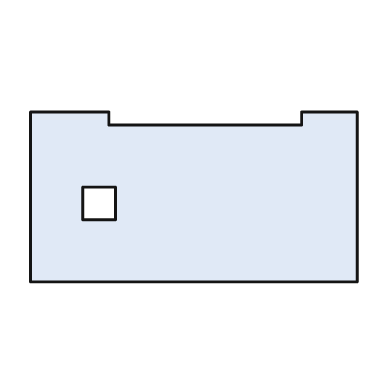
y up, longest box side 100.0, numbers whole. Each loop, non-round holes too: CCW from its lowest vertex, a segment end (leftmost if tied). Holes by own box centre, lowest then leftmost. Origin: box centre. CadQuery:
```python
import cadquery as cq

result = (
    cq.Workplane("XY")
    .moveTo(-50.0, -26.0)
    .lineTo(50.0, -26.0)
    .lineTo(50.0, 26.0)
    .lineTo(33.0, 26.0)
    .lineTo(33.0, 22.0)
    .lineTo(-26.0, 22.0)
    .lineTo(-26.0, 26.0)
    .lineTo(-50.0, 26.0)
    .close()
    .moveTo(-34.0, -7.0)
    .lineTo(-24.0, -7.0)
    .lineTo(-24.0, 3.0)
    .lineTo(-34.0, 3.0)
    .close()
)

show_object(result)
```